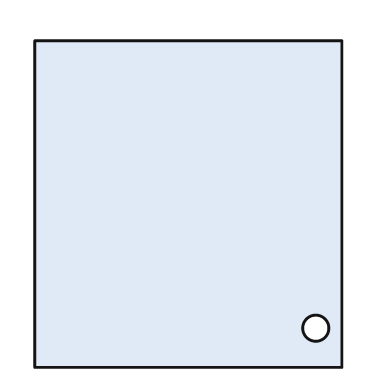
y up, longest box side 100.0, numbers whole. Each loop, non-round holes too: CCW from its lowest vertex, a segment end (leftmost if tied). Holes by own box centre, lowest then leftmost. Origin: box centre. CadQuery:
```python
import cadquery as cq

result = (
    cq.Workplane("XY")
    .moveTo(-47.0, -50.0)
    .lineTo(47.0, -50.0)
    .lineTo(47.0, 50.0)
    .lineTo(-47.0, 50.0)
    .close()
    .moveTo(39.0, -38.0)
    .circle(4.0)
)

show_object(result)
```